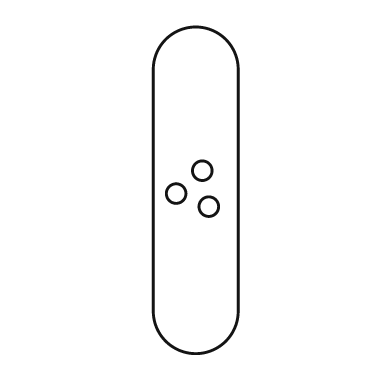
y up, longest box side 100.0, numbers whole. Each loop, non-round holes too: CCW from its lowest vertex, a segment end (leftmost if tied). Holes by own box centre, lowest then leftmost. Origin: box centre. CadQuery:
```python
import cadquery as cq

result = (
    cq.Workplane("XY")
    .moveTo(-13.0, -37.0)
    .threePointArc((0.0, -50.0), (13.0, -37.0))
    .lineTo(13.0, 37.0)
    .threePointArc((0.0, 50.0), (-13.0, 37.0))
    .close()
    .moveTo(4.0, -5.0)
    .circle(3.0)
    .moveTo(-6.0, -1.0)
    .circle(3.0)
    .moveTo(2.0, 6.0)
    .circle(3.0)
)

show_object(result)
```